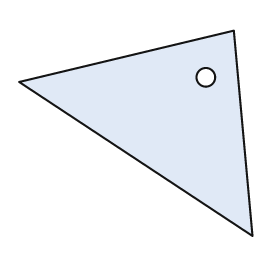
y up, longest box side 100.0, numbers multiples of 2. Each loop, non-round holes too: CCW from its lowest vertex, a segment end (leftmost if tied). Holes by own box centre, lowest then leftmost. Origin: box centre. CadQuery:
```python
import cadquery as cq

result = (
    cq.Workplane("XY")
    .moveTo(50.0, -44.0)
    .lineTo(42.0, 44.0)
    .lineTo(-50.0, 22.0)
    .close()
    .moveTo(30.0, 24.0)
    .circle(4.0)
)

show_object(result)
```